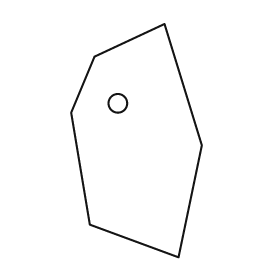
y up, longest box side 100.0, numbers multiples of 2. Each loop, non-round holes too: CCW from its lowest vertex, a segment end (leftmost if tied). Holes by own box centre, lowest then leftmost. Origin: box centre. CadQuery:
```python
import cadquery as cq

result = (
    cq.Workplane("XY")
    .moveTo(18.0, -50.0)
    .lineTo(28.0, -2.0)
    .lineTo(12.0, 50.0)
    .lineTo(-18.0, 36.0)
    .lineTo(-28.0, 12.0)
    .lineTo(-20.0, -36.0)
    .close()
    .moveTo(-8.0, 16.0)
    .circle(4.0)
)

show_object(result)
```